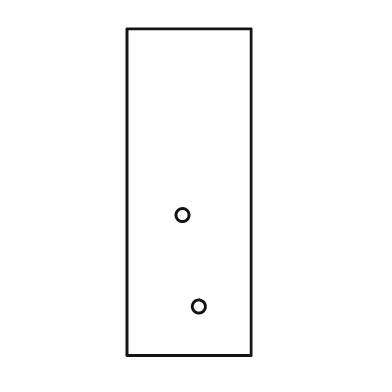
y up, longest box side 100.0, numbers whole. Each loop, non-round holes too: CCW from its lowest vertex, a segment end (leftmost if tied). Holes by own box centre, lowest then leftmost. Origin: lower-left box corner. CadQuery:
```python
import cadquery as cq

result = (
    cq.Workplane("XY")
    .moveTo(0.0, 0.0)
    .lineTo(38.0, 0.0)
    .lineTo(38.0, 100.0)
    .lineTo(0.0, 100.0)
    .close()
    .moveTo(22.0, 15.0)
    .circle(2.0)
    .moveTo(17.0, 43.0)
    .circle(2.0)
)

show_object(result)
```